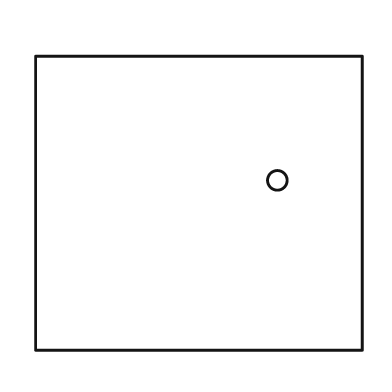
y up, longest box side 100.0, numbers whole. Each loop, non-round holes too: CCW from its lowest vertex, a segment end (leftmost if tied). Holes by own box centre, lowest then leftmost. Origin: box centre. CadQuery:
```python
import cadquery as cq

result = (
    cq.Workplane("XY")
    .moveTo(-50.0, -45.0)
    .lineTo(50.0, -45.0)
    .lineTo(50.0, 45.0)
    .lineTo(-50.0, 45.0)
    .close()
    .moveTo(24.0, 7.0)
    .circle(3.0)
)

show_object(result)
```